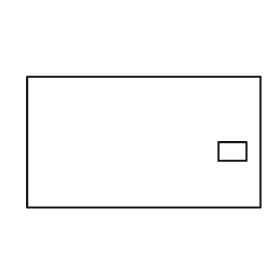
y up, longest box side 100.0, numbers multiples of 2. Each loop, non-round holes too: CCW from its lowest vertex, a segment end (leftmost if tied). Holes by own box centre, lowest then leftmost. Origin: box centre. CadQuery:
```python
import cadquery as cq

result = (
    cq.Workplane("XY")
    .moveTo(-50.0, -28.0)
    .lineTo(50.0, -28.0)
    .lineTo(50.0, 28.0)
    .lineTo(-50.0, 28.0)
    .close()
    .moveTo(32.0, -8.0)
    .lineTo(44.0, -8.0)
    .lineTo(44.0, 0.0)
    .lineTo(32.0, 0.0)
    .close()
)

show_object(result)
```